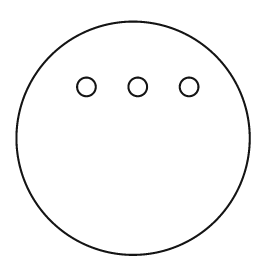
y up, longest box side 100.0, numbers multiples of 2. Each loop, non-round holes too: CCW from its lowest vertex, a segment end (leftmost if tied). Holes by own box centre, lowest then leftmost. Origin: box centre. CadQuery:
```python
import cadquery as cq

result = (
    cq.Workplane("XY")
    .moveTo(0.0, 0.0)
    .circle(50.0)
    .moveTo(-20.0, 22.0)
    .circle(4.0)
    .moveTo(2.0, 22.0)
    .circle(4.0)
    .moveTo(24.0, 22.0)
    .circle(4.0)
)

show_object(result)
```